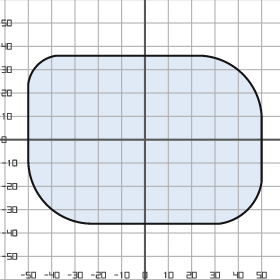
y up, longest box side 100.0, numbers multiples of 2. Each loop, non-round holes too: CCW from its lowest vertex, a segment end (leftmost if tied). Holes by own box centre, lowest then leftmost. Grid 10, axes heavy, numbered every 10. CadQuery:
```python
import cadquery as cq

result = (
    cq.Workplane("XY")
    .moveTo(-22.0, -36.0)
    .lineTo(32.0, -36.0)
    .threePointArc((44.0, -30.0), (50.0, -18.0))
    .lineTo(50.0, 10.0)
    .threePointArc((42.0, 28.0), (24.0, 36.0))
    .lineTo(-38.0, 36.0)
    .threePointArc((-46.0, 32.0), (-50.0, 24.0))
    .lineTo(-50.0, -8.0)
    .threePointArc((-42.0, -28.0), (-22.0, -36.0))
    .close()
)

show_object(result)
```